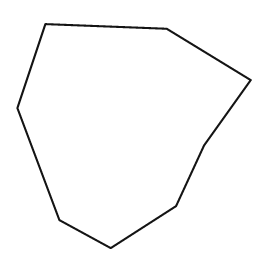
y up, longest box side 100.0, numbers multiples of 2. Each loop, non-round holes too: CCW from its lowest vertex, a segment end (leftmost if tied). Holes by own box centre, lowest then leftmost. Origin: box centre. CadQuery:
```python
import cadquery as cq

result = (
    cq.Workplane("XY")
    .moveTo(-10.0, -48.0)
    .lineTo(18.0, -30.0)
    .lineTo(30.0, -4.0)
    .lineTo(50.0, 24.0)
    .lineTo(14.0, 46.0)
    .lineTo(-38.0, 48.0)
    .lineTo(-50.0, 12.0)
    .lineTo(-32.0, -36.0)
    .close()
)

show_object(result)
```